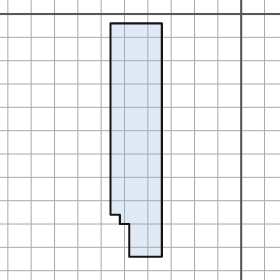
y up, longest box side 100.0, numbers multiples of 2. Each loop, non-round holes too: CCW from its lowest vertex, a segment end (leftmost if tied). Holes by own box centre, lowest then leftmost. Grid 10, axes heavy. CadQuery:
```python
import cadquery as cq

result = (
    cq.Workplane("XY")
    .moveTo(-48.0, -104.0)
    .lineTo(-34.0, -104.0)
    .lineTo(-34.0, -4.0)
    .lineTo(-56.0, -4.0)
    .lineTo(-56.0, -86.0)
    .lineTo(-52.0, -86.0)
    .lineTo(-52.0, -90.0)
    .lineTo(-48.0, -90.0)
    .close()
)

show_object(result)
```